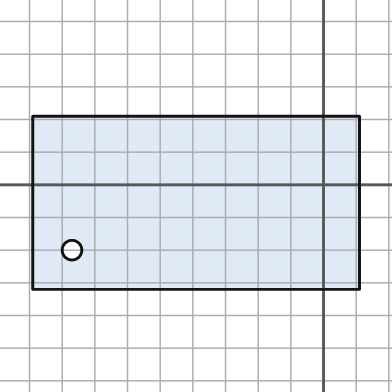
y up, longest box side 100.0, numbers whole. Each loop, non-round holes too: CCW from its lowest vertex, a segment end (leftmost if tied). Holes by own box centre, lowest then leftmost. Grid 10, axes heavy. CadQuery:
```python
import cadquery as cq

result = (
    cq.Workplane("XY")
    .moveTo(-89.0, -32.0)
    .lineTo(11.0, -32.0)
    .lineTo(11.0, 21.0)
    .lineTo(-89.0, 21.0)
    .close()
    .moveTo(-77.0, -20.0)
    .circle(3.0)
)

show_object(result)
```